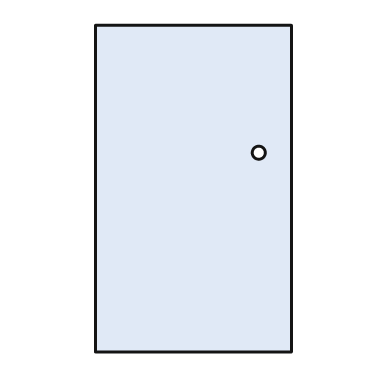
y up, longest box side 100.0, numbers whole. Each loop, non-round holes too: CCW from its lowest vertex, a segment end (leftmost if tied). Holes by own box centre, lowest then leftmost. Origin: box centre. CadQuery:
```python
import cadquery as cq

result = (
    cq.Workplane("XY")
    .moveTo(-30.0, -50.0)
    .lineTo(30.0, -50.0)
    .lineTo(30.0, 50.0)
    .lineTo(-30.0, 50.0)
    .close()
    .moveTo(20.0, 11.0)
    .circle(2.0)
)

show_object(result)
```